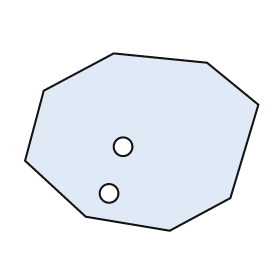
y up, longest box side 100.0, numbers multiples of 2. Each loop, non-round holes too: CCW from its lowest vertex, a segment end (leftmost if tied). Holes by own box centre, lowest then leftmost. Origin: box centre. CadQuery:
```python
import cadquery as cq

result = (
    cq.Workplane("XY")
    .moveTo(12.0, -38.0)
    .lineTo(38.0, -24.0)
    .lineTo(50.0, 16.0)
    .lineTo(28.0, 34.0)
    .lineTo(-12.0, 38.0)
    .lineTo(-42.0, 22.0)
    .lineTo(-50.0, -8.0)
    .lineTo(-24.0, -32.0)
    .close()
    .moveTo(-14.0, -22.0)
    .circle(4.0)
    .moveTo(-8.0, -2.0)
    .circle(4.0)
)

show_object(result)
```